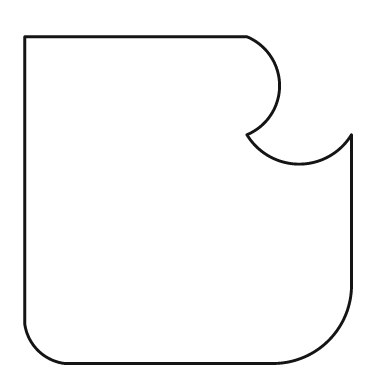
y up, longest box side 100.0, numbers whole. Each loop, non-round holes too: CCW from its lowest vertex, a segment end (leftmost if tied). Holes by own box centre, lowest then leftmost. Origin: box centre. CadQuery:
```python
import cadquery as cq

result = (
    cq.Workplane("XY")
    .moveTo(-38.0, -50.0)
    .lineTo(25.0, -50.0)
    .threePointArc((43.0, -43.0), (50.0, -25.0))
    .lineTo(50.0, 20.0)
    .threePointArc((34.0, 11.0), (18.0, 20.0))
    .threePointArc((28.0, 35.0), (18.0, 50.0))
    .lineTo(-50.0, 50.0)
    .lineTo(-50.0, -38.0)
    .threePointArc((-46.0, -46.0), (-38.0, -50.0))
    .close()
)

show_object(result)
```